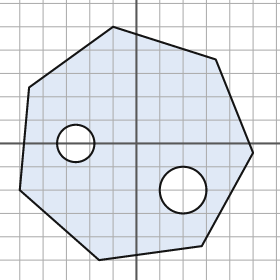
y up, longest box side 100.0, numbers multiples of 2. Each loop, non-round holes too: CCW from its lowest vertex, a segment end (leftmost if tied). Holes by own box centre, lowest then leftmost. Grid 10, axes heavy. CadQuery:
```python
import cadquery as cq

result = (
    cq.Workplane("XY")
    .moveTo(-16.0, -50.0)
    .lineTo(28.0, -44.0)
    .lineTo(50.0, -4.0)
    .lineTo(34.0, 36.0)
    .lineTo(-10.0, 50.0)
    .lineTo(-46.0, 24.0)
    .lineTo(-50.0, -20.0)
    .close()
    .moveTo(20.0, -20.0)
    .circle(10.0)
    .moveTo(-26.0, 0.0)
    .circle(8.0)
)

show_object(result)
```